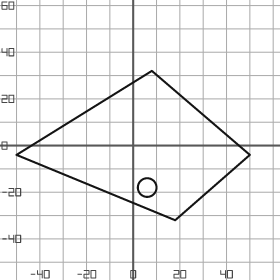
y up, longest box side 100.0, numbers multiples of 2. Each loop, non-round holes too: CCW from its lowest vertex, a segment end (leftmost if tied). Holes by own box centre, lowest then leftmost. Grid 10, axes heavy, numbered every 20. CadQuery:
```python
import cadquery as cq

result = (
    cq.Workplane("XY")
    .moveTo(18.0, -32.0)
    .lineTo(50.0, -4.0)
    .lineTo(8.0, 32.0)
    .lineTo(-50.0, -4.0)
    .close()
    .moveTo(6.0, -18.0)
    .circle(4.0)
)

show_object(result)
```